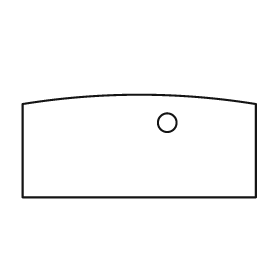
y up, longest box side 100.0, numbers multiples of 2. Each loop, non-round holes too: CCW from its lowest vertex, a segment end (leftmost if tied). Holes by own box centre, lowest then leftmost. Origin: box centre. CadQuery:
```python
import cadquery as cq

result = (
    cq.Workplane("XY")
    .moveTo(-50.0, -22.0)
    .lineTo(50.0, -22.0)
    .lineTo(50.0, 18.0)
    .threePointArc((0.0, 22.0), (-50.0, 18.0))
    .close()
    .moveTo(12.0, 10.0)
    .circle(4.0)
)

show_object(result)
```